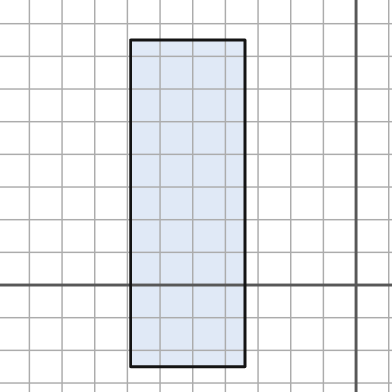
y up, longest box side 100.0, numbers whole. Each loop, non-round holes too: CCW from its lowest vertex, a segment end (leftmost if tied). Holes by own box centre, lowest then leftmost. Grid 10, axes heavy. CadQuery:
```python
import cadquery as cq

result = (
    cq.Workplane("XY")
    .moveTo(-69.0, -25.0)
    .lineTo(-34.0, -25.0)
    .lineTo(-34.0, 75.0)
    .lineTo(-69.0, 75.0)
    .close()
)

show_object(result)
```